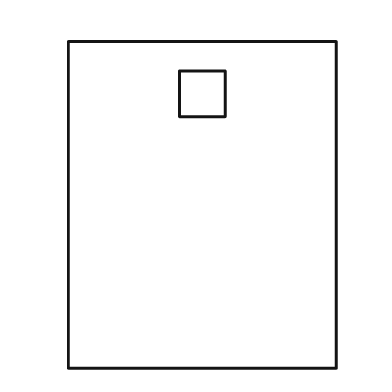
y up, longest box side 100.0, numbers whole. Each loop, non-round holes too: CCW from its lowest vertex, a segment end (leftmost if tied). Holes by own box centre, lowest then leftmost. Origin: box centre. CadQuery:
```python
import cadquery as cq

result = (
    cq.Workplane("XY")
    .moveTo(-41.0, -50.0)
    .lineTo(41.0, -50.0)
    .lineTo(41.0, 50.0)
    .lineTo(-41.0, 50.0)
    .close()
    .moveTo(-7.0, 27.0)
    .lineTo(7.0, 27.0)
    .lineTo(7.0, 41.0)
    .lineTo(-7.0, 41.0)
    .close()
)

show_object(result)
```